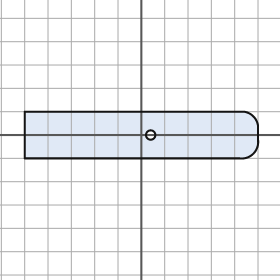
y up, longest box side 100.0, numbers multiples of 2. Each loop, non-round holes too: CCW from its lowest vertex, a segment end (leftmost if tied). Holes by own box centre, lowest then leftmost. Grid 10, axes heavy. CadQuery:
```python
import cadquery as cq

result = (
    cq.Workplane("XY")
    .moveTo(-50.0, -10.0)
    .lineTo(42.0, -10.0)
    .threePointArc((48.0, -8.0), (50.0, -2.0))
    .lineTo(50.0, 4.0)
    .threePointArc((48.0, 8.0), (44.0, 10.0))
    .lineTo(-50.0, 10.0)
    .close()
    .moveTo(4.0, 0.0)
    .circle(2.0)
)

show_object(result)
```